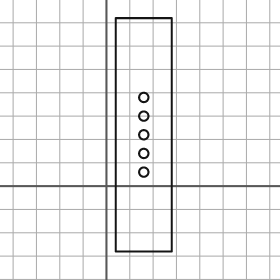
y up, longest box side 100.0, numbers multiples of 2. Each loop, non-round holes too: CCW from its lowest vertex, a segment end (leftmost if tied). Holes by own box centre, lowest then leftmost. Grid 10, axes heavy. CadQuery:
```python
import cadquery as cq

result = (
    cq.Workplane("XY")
    .moveTo(4.0, -28.0)
    .lineTo(28.0, -28.0)
    .lineTo(28.0, 72.0)
    .lineTo(4.0, 72.0)
    .close()
    .moveTo(16.0, 6.0)
    .circle(2.0)
    .moveTo(16.0, 14.0)
    .circle(2.0)
    .moveTo(16.0, 22.0)
    .circle(2.0)
    .moveTo(16.0, 30.0)
    .circle(2.0)
    .moveTo(16.0, 38.0)
    .circle(2.0)
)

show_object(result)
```